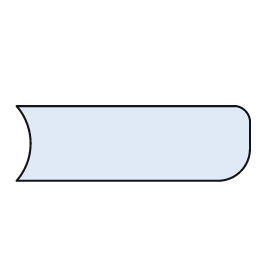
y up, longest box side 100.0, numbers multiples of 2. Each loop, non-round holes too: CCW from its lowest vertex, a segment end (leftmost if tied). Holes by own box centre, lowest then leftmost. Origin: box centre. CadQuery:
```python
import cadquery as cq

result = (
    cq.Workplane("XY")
    .moveTo(-50.0, -16.0)
    .lineTo(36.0, -16.0)
    .threePointArc((46.0, -12.0), (50.0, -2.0))
    .lineTo(50.0, 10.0)
    .threePointArc((48.0, 14.0), (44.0, 16.0))
    .lineTo(-50.0, 16.0)
    .threePointArc((-44.0, 0.0), (-50.0, -16.0))
    .close()
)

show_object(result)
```